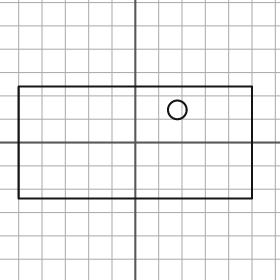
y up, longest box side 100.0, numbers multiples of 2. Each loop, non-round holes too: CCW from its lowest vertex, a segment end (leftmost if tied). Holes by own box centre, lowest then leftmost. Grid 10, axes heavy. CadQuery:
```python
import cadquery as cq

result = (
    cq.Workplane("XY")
    .moveTo(-50.0, -24.0)
    .lineTo(50.0, -24.0)
    .lineTo(50.0, 24.0)
    .lineTo(-50.0, 24.0)
    .close()
    .moveTo(18.0, 14.0)
    .circle(4.0)
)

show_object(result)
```